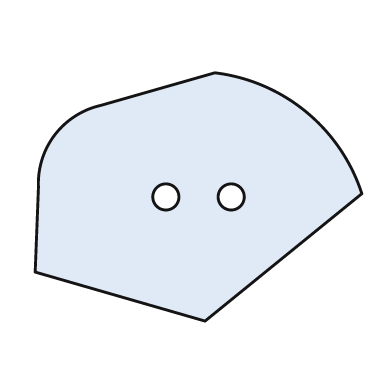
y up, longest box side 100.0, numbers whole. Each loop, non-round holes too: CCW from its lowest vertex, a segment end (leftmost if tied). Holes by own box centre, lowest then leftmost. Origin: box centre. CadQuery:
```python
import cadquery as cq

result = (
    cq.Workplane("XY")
    .moveTo(2.0, -38.0)
    .lineTo(50.0, 1.0)
    .threePointArc((33.0, 26.0), (5.0, 38.0))
    .lineTo(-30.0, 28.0)
    .threePointArc((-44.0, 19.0), (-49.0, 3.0))
    .lineTo(-50.0, -23.0)
    .close()
    .moveTo(-10.0, 0.0)
    .circle(4.0)
    .moveTo(10.0, 0.0)
    .circle(4.0)
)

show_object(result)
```